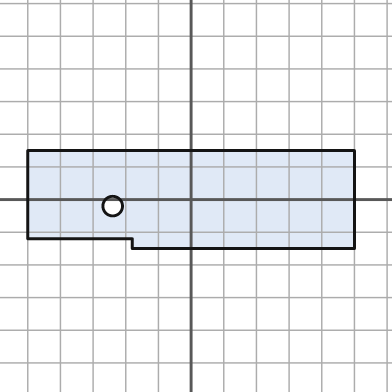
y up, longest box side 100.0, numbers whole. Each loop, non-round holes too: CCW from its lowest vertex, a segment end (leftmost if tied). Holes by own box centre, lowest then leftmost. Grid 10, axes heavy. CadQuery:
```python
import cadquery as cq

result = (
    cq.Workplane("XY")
    .moveTo(-18.0, -15.0)
    .lineTo(50.0, -15.0)
    .lineTo(50.0, 15.0)
    .lineTo(-50.0, 15.0)
    .lineTo(-50.0, -12.0)
    .lineTo(-18.0, -12.0)
    .close()
    .moveTo(-24.0, -2.0)
    .circle(3.0)
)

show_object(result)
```